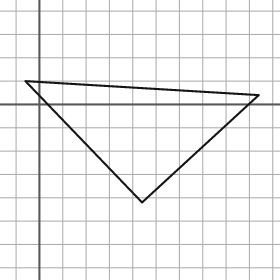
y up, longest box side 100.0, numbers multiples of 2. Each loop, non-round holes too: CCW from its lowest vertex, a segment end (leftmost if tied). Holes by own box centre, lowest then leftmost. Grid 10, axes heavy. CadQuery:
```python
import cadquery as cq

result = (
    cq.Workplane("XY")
    .moveTo(44.0, -42.0)
    .lineTo(94.0, 4.0)
    .lineTo(-6.0, 10.0)
    .close()
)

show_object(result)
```